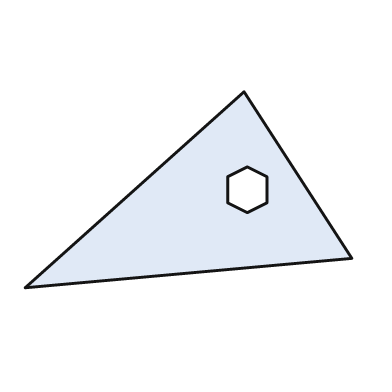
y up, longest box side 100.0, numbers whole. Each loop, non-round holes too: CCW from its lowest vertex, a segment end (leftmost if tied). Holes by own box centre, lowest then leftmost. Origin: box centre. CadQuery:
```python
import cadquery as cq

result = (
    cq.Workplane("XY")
    .moveTo(-50.0, -30.0)
    .lineTo(50.0, -21.0)
    .lineTo(17.0, 30.0)
    .close()
    .moveTo(18.0, -7.0)
    .lineTo(24.0, -4.0)
    .lineTo(24.0, 4.0)
    .lineTo(18.0, 7.0)
    .lineTo(12.0, 4.0)
    .lineTo(12.0, -4.0)
    .close()
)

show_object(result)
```